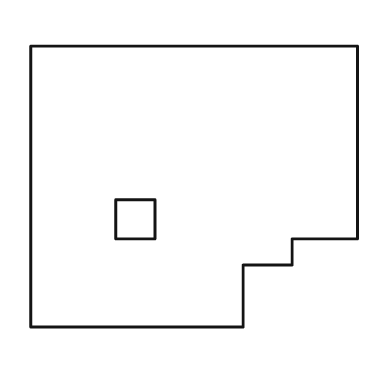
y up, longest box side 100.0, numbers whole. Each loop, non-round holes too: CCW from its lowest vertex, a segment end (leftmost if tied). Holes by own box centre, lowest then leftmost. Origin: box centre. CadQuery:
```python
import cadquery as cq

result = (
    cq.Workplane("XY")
    .moveTo(-50.0, -43.0)
    .lineTo(15.0, -43.0)
    .lineTo(15.0, -24.0)
    .lineTo(30.0, -24.0)
    .lineTo(30.0, -16.0)
    .lineTo(50.0, -16.0)
    .lineTo(50.0, 43.0)
    .lineTo(-50.0, 43.0)
    .close()
    .moveTo(-24.0, -16.0)
    .lineTo(-12.0, -16.0)
    .lineTo(-12.0, -4.0)
    .lineTo(-24.0, -4.0)
    .close()
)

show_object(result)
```